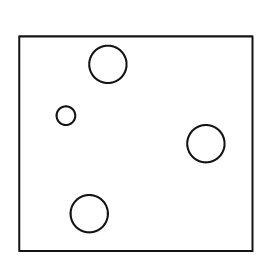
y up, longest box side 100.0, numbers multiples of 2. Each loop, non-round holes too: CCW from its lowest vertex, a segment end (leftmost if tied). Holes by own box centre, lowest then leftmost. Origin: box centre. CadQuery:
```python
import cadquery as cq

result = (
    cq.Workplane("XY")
    .moveTo(-50.0, -46.0)
    .lineTo(50.0, -46.0)
    .lineTo(50.0, 46.0)
    .lineTo(-50.0, 46.0)
    .close()
    .moveTo(-20.0, -30.0)
    .circle(8.0)
    .moveTo(30.0, 0.0)
    .circle(8.0)
    .moveTo(-30.0, 12.0)
    .circle(4.0)
    .moveTo(-12.0, 34.0)
    .circle(8.0)
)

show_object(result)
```